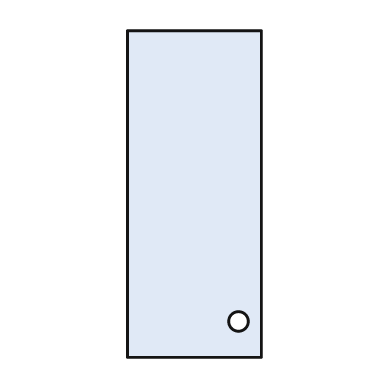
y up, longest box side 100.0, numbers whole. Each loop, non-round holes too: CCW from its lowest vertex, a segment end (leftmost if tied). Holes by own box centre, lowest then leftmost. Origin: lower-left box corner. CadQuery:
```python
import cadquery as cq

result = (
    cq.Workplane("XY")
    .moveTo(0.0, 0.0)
    .lineTo(41.0, 0.0)
    .lineTo(41.0, 100.0)
    .lineTo(0.0, 100.0)
    .close()
    .moveTo(34.0, 11.0)
    .circle(3.0)
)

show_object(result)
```